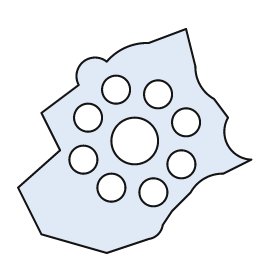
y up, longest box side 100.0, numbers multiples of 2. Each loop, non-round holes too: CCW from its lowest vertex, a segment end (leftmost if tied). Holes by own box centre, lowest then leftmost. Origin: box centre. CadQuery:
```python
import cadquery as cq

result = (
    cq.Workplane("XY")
    .moveTo(-12.0, -48.0)
    .lineTo(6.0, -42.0)
    .threePointArc((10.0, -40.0), (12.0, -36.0))
    .lineTo(16.0, -30.0)
    .lineTo(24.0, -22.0)
    .threePointArc((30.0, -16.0), (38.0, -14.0))
    .lineTo(50.0, -8.0)
    .threePointArc((40.0, -2.0), (40.0, 10.0))
    .lineTo(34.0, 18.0)
    .threePointArc((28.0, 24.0), (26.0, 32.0))
    .lineTo(22.0, 48.0)
    .lineTo(6.0, 42.0)
    .threePointArc((-4.0, 40.0), (-12.0, 34.0))
    .threePointArc((-22.0, 34.0), (-24.0, 24.0))
    .lineTo(-40.0, 12.0)
    .lineTo(-32.0, -4.0)
    .lineTo(-50.0, -20.0)
    .lineTo(-40.0, -40.0)
    .close()
    .moveTo(8.0, -22.0)
    .circle(6.0)
    .moveTo(-10.0, -20.0)
    .circle(6.0)
    .moveTo(20.0, -10.0)
    .circle(6.0)
    .moveTo(-22.0, -8.0)
    .circle(6.0)
    .moveTo(0.0, 0.0)
    .circle(10.0)
    .moveTo(22.0, 8.0)
    .circle(6.0)
    .moveTo(-20.0, 10.0)
    .circle(6.0)
    .moveTo(10.0, 20.0)
    .circle(6.0)
    .moveTo(-8.0, 22.0)
    .circle(6.0)
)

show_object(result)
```